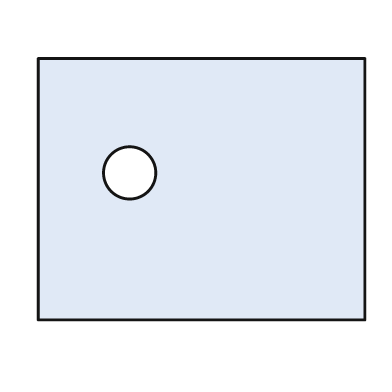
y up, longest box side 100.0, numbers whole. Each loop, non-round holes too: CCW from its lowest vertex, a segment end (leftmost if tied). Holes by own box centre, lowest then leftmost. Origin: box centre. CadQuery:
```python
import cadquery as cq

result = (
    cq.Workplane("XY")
    .moveTo(-50.0, -40.0)
    .lineTo(50.0, -40.0)
    .lineTo(50.0, 40.0)
    .lineTo(-50.0, 40.0)
    .close()
    .moveTo(-22.0, 5.0)
    .circle(8.0)
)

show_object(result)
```